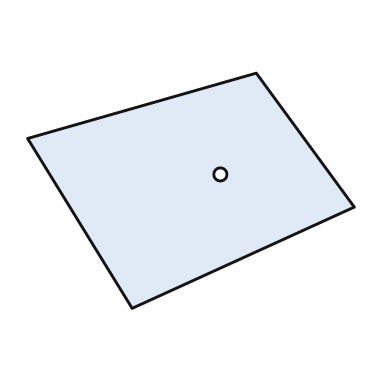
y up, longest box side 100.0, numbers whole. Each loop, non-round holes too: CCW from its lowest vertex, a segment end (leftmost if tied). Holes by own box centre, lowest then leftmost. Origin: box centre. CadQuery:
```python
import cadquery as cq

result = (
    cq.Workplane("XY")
    .moveTo(-18.0, -36.0)
    .lineTo(50.0, -5.0)
    .lineTo(20.0, 36.0)
    .lineTo(-50.0, 16.0)
    .close()
    .moveTo(9.0, 5.0)
    .circle(2.0)
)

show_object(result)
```